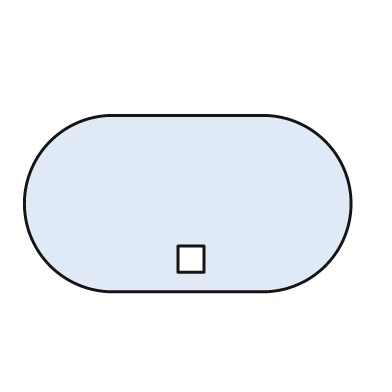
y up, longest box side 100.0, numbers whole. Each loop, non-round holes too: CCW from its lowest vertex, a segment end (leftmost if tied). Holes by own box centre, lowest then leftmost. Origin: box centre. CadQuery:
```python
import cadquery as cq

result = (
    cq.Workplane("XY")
    .moveTo(-23.0, -27.0)
    .lineTo(23.0, -27.0)
    .threePointArc((50.0, 0.0), (23.0, 27.0))
    .lineTo(-23.0, 27.0)
    .threePointArc((-50.0, 0.0), (-23.0, -27.0))
    .close()
    .moveTo(-3.0, -21.0)
    .lineTo(5.0, -21.0)
    .lineTo(5.0, -13.0)
    .lineTo(-3.0, -13.0)
    .close()
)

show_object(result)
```